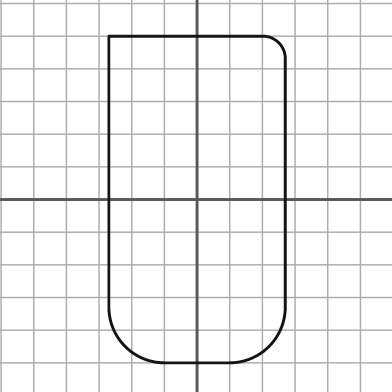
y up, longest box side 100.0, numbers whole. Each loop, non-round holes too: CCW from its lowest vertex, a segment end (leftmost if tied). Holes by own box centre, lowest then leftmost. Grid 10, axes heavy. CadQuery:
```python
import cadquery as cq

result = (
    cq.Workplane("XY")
    .moveTo(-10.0, -50.0)
    .lineTo(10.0, -50.0)
    .threePointArc((22.0, -45.0), (27.0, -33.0))
    .lineTo(27.0, 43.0)
    .threePointArc((25.0, 48.0), (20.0, 50.0))
    .lineTo(-27.0, 50.0)
    .lineTo(-27.0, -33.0)
    .threePointArc((-22.0, -45.0), (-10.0, -50.0))
    .close()
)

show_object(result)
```